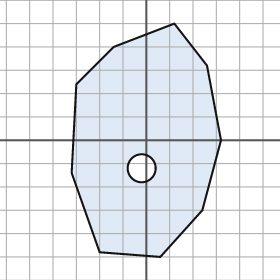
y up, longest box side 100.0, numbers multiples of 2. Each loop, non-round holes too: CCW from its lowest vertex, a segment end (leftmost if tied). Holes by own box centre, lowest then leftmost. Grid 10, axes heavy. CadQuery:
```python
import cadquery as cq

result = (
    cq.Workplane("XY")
    .moveTo(6.0, -50.0)
    .lineTo(24.0, -30.0)
    .lineTo(32.0, 0.0)
    .lineTo(26.0, 32.0)
    .lineTo(12.0, 50.0)
    .lineTo(-14.0, 40.0)
    .lineTo(-30.0, 24.0)
    .lineTo(-32.0, -14.0)
    .lineTo(-20.0, -48.0)
    .close()
    .moveTo(-2.0, -12.0)
    .circle(6.0)
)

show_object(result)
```